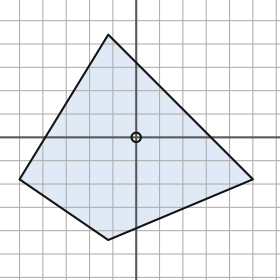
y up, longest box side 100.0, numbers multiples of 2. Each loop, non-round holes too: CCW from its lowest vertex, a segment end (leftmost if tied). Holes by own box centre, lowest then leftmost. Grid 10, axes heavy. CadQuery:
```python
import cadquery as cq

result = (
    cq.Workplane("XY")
    .moveTo(-12.0, -44.0)
    .lineTo(50.0, -18.0)
    .lineTo(-12.0, 44.0)
    .lineTo(-50.0, -18.0)
    .close()
    .moveTo(0.0, 0.0)
    .circle(2.0)
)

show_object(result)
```